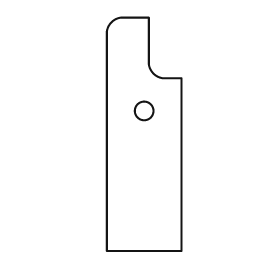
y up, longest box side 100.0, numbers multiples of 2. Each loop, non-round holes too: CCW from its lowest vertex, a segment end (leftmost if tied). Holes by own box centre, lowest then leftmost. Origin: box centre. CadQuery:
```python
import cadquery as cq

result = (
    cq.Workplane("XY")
    .moveTo(-16.0, -50.0)
    .lineTo(16.0, -50.0)
    .lineTo(16.0, 24.0)
    .lineTo(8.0, 24.0)
    .threePointArc((4.0, 26.0), (2.0, 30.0))
    .lineTo(2.0, 50.0)
    .lineTo(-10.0, 50.0)
    .threePointArc((-14.0, 48.0), (-16.0, 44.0))
    .close()
    .moveTo(0.0, 10.0)
    .circle(4.0)
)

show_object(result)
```